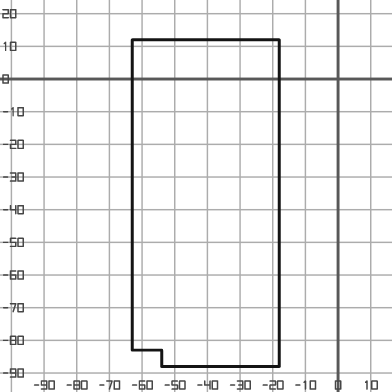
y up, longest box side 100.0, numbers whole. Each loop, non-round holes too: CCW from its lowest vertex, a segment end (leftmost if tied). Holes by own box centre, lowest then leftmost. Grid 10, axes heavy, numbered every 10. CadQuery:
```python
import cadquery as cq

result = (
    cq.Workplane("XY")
    .moveTo(-54.0, -88.0)
    .lineTo(-18.0, -88.0)
    .lineTo(-18.0, 12.0)
    .lineTo(-63.0, 12.0)
    .lineTo(-63.0, -83.0)
    .lineTo(-54.0, -83.0)
    .close()
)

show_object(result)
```